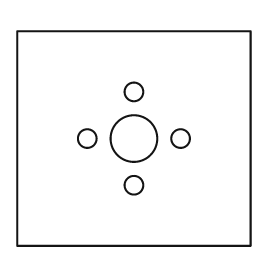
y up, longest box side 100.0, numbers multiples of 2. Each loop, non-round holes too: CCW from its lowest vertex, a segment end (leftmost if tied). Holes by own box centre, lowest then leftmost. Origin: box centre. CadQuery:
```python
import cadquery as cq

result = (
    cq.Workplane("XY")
    .moveTo(-50.0, -46.0)
    .lineTo(50.0, -46.0)
    .lineTo(50.0, 46.0)
    .lineTo(-50.0, 46.0)
    .close()
    .moveTo(0.0, -20.0)
    .circle(4.0)
    .moveTo(-20.0, 0.0)
    .circle(4.0)
    .moveTo(0.0, 0.0)
    .circle(10.0)
    .moveTo(20.0, 0.0)
    .circle(4.0)
    .moveTo(0.0, 20.0)
    .circle(4.0)
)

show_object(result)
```